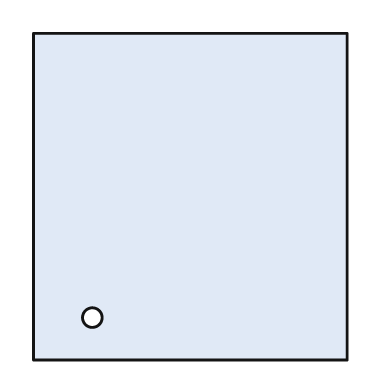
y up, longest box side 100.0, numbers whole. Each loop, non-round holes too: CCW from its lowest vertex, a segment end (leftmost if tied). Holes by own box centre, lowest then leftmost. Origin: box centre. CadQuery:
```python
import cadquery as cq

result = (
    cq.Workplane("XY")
    .moveTo(-48.0, -50.0)
    .lineTo(48.0, -50.0)
    .lineTo(48.0, 50.0)
    .lineTo(-48.0, 50.0)
    .close()
    .moveTo(-30.0, -37.0)
    .circle(3.0)
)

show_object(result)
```